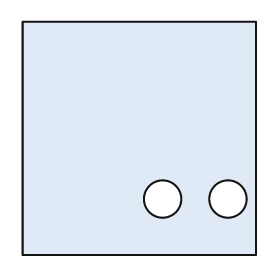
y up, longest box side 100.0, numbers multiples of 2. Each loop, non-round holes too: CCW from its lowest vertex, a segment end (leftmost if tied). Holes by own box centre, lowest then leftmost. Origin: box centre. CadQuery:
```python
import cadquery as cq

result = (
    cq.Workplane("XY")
    .moveTo(-50.0, -50.0)
    .lineTo(50.0, -50.0)
    .lineTo(50.0, 50.0)
    .lineTo(-50.0, 50.0)
    .close()
    .moveTo(10.0, -26.0)
    .circle(8.0)
    .moveTo(38.0, -26.0)
    .circle(8.0)
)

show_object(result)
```